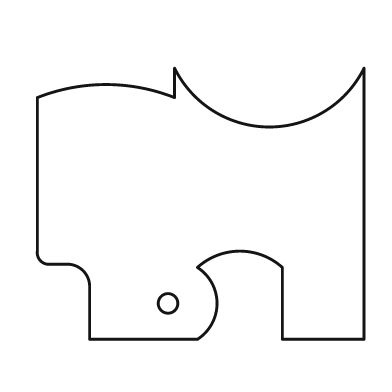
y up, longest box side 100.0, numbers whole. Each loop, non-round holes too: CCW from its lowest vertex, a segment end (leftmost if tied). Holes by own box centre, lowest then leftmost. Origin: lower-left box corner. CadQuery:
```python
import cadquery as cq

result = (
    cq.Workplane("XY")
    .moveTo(16.0, 0.0)
    .lineTo(49.0, 0.0)
    .threePointArc((55.0, 11.0), (49.0, 22.0))
    .threePointArc((62.0, 27.0), (75.0, 22.0))
    .lineTo(75.0, 0.0)
    .lineTo(100.0, 0.0)
    .lineTo(100.0, 83.0)
    .threePointArc((71.0, 65.0), (42.0, 83.0))
    .lineTo(42.0, 74.0)
    .threePointArc((21.0, 78.0), (0.0, 74.0))
    .lineTo(0.0, 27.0)
    .threePointArc((1.0, 24.0), (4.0, 23.0))
    .lineTo(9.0, 23.0)
    .threePointArc((14.0, 21.0), (16.0, 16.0))
    .close()
    .moveTo(40.0, 11.0)
    .circle(3.0)
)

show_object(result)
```